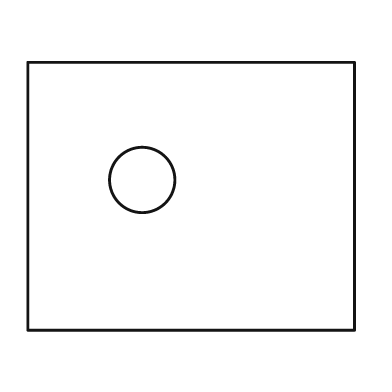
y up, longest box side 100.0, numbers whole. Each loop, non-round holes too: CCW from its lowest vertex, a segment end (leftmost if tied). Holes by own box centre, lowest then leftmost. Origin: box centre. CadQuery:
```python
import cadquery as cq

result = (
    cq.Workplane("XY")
    .moveTo(-50.0, -41.0)
    .lineTo(50.0, -41.0)
    .lineTo(50.0, 41.0)
    .lineTo(-50.0, 41.0)
    .close()
    .moveTo(-15.0, 5.0)
    .circle(10.0)
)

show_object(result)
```